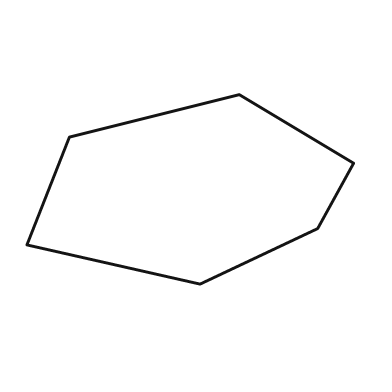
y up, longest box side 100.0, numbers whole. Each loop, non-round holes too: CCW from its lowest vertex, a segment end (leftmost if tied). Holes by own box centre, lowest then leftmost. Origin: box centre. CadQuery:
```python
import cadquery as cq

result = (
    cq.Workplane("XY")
    .moveTo(3.0, -29.0)
    .lineTo(39.0, -12.0)
    .lineTo(50.0, 8.0)
    .lineTo(15.0, 29.0)
    .lineTo(-37.0, 16.0)
    .lineTo(-50.0, -17.0)
    .close()
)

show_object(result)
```